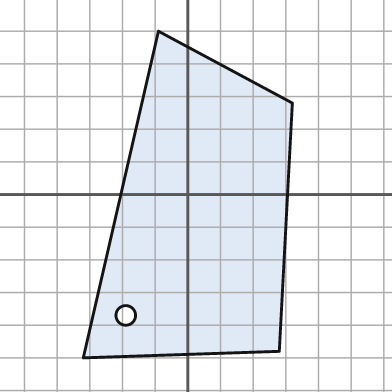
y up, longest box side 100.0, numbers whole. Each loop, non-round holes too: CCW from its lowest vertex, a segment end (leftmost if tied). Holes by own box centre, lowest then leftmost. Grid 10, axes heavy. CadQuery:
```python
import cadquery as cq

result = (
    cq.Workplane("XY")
    .moveTo(-32.0, -50.0)
    .lineTo(28.0, -48.0)
    .lineTo(32.0, 28.0)
    .lineTo(-9.0, 50.0)
    .close()
    .moveTo(-19.0, -37.0)
    .circle(3.0)
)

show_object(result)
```